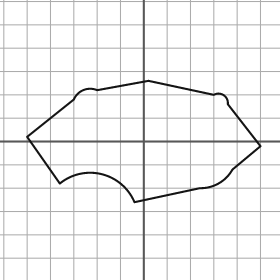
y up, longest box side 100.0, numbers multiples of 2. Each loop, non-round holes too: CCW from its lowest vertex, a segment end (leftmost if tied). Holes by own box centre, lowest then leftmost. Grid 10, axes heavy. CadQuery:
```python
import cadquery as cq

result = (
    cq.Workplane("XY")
    .moveTo(-4.0, -26.0)
    .lineTo(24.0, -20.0)
    .threePointArc((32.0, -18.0), (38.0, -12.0))
    .lineTo(50.0, -2.0)
    .lineTo(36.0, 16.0)
    .threePointArc((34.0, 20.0), (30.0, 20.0))
    .lineTo(2.0, 26.0)
    .lineTo(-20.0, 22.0)
    .threePointArc((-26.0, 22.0), (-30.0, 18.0))
    .lineTo(-50.0, 2.0)
    .lineTo(-36.0, -18.0)
    .threePointArc((-18.0, -14.0), (-4.0, -26.0))
    .close()
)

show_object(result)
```